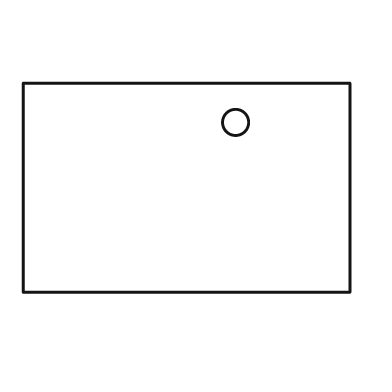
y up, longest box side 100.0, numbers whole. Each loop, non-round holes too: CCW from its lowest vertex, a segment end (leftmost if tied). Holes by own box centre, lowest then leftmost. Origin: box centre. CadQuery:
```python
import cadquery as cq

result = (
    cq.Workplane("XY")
    .moveTo(-50.0, -32.0)
    .lineTo(50.0, -32.0)
    .lineTo(50.0, 32.0)
    .lineTo(-50.0, 32.0)
    .close()
    .moveTo(15.0, 20.0)
    .circle(4.0)
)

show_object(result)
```